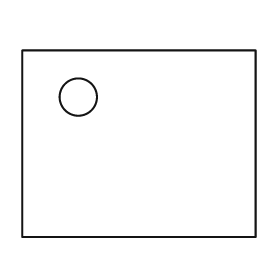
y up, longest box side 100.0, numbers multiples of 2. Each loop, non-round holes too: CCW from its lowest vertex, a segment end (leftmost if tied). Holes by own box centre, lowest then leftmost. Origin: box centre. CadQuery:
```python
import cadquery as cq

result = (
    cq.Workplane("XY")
    .moveTo(-50.0, -40.0)
    .lineTo(50.0, -40.0)
    .lineTo(50.0, 40.0)
    .lineTo(-50.0, 40.0)
    .close()
    .moveTo(-26.0, 20.0)
    .circle(8.0)
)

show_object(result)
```